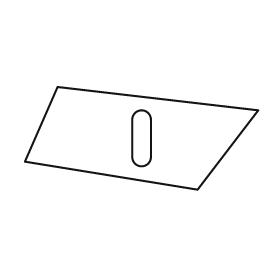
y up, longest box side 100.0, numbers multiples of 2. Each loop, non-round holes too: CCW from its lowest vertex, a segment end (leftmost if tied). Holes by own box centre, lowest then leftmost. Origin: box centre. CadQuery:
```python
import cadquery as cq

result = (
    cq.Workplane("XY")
    .moveTo(24.0, -22.0)
    .lineTo(50.0, 12.0)
    .lineTo(-36.0, 22.0)
    .lineTo(-50.0, -10.0)
    .close()
    .moveTo(-4.0, -8.0)
    .threePointArc((0.0, -12.0), (4.0, -8.0))
    .lineTo(4.0, 8.0)
    .threePointArc((0.0, 12.0), (-4.0, 8.0))
    .close()
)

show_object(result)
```